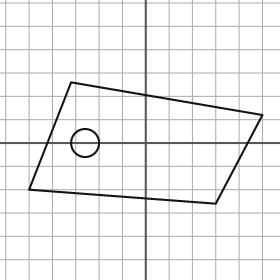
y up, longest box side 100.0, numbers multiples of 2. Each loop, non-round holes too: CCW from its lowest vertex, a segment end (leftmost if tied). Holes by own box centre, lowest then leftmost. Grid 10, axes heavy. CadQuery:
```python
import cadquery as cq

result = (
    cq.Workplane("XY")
    .moveTo(30.0, -26.0)
    .lineTo(50.0, 12.0)
    .lineTo(-32.0, 26.0)
    .lineTo(-50.0, -20.0)
    .close()
    .moveTo(-26.0, 0.0)
    .circle(6.0)
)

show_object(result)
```